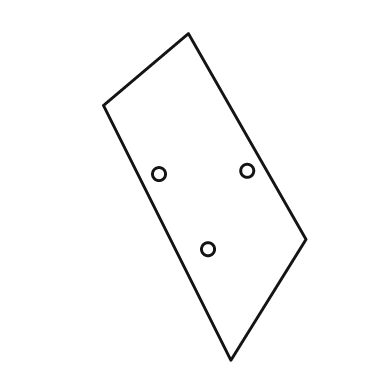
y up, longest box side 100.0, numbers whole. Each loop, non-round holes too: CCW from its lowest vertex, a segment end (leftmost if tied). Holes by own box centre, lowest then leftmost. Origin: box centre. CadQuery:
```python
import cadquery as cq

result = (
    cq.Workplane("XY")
    .moveTo(8.0, -50.0)
    .lineTo(31.0, -13.0)
    .lineTo(-5.0, 50.0)
    .lineTo(-31.0, 28.0)
    .close()
    .moveTo(1.0, -16.0)
    .circle(2.0)
    .moveTo(-14.0, 7.0)
    .circle(2.0)
    .moveTo(13.0, 8.0)
    .circle(2.0)
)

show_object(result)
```